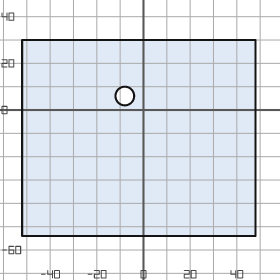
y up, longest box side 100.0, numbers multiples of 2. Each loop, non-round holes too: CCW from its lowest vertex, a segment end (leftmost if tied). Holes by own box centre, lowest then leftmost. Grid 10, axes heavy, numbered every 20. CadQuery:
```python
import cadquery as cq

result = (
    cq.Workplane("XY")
    .moveTo(-52.0, -54.0)
    .lineTo(48.0, -54.0)
    .lineTo(48.0, 30.0)
    .lineTo(-52.0, 30.0)
    .close()
    .moveTo(-8.0, 6.0)
    .circle(4.0)
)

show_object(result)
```